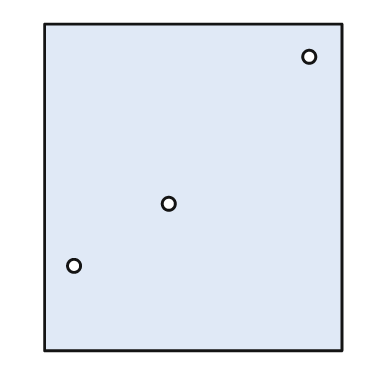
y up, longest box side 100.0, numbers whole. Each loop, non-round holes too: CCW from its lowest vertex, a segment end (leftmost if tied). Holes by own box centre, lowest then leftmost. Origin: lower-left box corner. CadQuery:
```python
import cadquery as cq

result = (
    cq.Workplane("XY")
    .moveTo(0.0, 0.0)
    .lineTo(91.0, 0.0)
    .lineTo(91.0, 100.0)
    .lineTo(0.0, 100.0)
    .close()
    .moveTo(9.0, 26.0)
    .circle(2.0)
    .moveTo(38.0, 45.0)
    .circle(2.0)
    .moveTo(81.0, 90.0)
    .circle(2.0)
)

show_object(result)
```